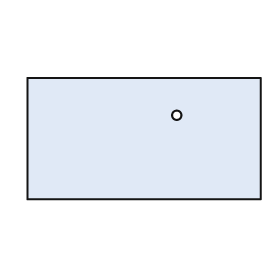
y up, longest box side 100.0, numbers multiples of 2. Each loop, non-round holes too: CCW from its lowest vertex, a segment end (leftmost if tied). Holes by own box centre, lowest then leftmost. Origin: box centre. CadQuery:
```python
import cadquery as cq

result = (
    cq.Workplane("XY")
    .moveTo(-50.0, -26.0)
    .lineTo(50.0, -26.0)
    .lineTo(50.0, 26.0)
    .lineTo(-50.0, 26.0)
    .close()
    .moveTo(14.0, 10.0)
    .circle(2.0)
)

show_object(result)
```